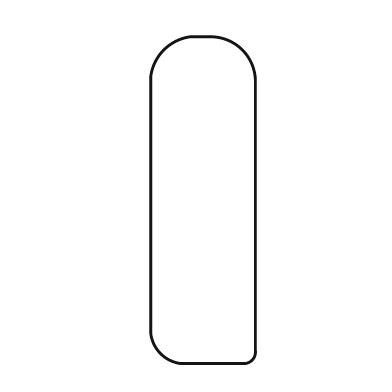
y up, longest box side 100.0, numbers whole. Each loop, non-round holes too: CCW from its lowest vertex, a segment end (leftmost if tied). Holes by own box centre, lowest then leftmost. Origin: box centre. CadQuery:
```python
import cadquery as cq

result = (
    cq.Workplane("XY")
    .moveTo(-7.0, -50.0)
    .lineTo(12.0, -50.0)
    .threePointArc((15.0, -49.0), (16.0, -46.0))
    .lineTo(16.0, 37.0)
    .threePointArc((12.0, 46.0), (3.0, 50.0))
    .lineTo(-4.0, 50.0)
    .threePointArc((-12.0, 46.0), (-16.0, 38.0))
    .lineTo(-16.0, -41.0)
    .threePointArc((-13.0, -47.0), (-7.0, -50.0))
    .close()
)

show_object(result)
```